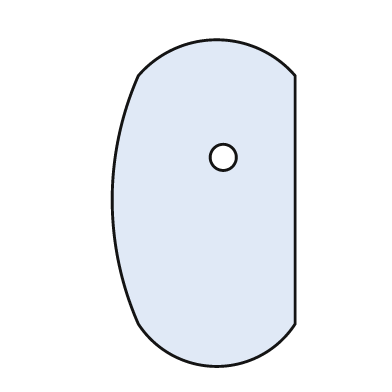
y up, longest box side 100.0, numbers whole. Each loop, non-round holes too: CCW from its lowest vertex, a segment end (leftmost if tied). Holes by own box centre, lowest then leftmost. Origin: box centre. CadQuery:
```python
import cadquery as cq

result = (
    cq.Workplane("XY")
    .moveTo(-20.0, -37.0)
    .threePointArc((4.0, -50.0), (28.0, -37.0))
    .lineTo(28.0, 39.0)
    .threePointArc((4.0, 50.0), (-20.0, 39.0))
    .threePointArc((-28.0, 1.0), (-20.0, -37.0))
    .close()
    .moveTo(6.0, 14.0)
    .circle(4.0)
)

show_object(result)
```